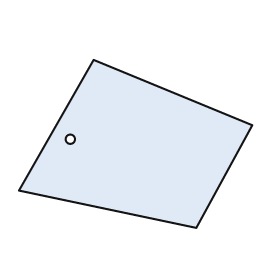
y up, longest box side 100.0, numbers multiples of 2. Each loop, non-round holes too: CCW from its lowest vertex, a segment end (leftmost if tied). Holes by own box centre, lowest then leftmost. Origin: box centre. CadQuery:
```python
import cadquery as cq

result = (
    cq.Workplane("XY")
    .moveTo(26.0, -36.0)
    .lineTo(50.0, 8.0)
    .lineTo(-18.0, 36.0)
    .lineTo(-50.0, -20.0)
    .close()
    .moveTo(-28.0, 2.0)
    .circle(2.0)
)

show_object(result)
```